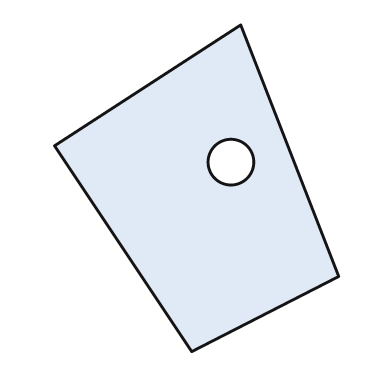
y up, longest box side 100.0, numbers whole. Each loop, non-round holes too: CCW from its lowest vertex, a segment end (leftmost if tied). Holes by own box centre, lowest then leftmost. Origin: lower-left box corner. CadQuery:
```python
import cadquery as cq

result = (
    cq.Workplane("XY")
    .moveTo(42.0, 0.0)
    .lineTo(87.0, 23.0)
    .lineTo(57.0, 100.0)
    .lineTo(0.0, 63.0)
    .close()
    .moveTo(54.0, 58.0)
    .circle(7.0)
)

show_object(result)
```